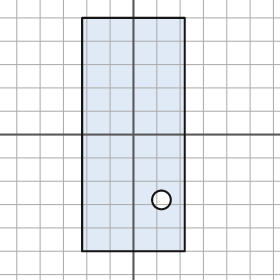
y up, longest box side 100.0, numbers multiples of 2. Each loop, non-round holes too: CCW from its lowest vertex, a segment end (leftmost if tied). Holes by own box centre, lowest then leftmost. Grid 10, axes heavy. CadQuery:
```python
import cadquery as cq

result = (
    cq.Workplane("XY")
    .moveTo(-22.0, -50.0)
    .lineTo(22.0, -50.0)
    .lineTo(22.0, 50.0)
    .lineTo(-22.0, 50.0)
    .close()
    .moveTo(12.0, -28.0)
    .circle(4.0)
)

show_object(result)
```